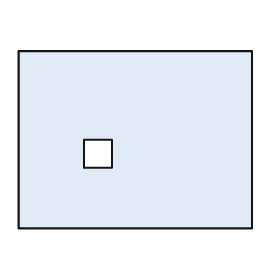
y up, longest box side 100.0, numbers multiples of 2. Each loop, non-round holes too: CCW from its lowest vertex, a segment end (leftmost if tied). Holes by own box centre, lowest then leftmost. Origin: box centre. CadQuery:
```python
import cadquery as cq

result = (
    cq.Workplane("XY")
    .moveTo(-50.0, -38.0)
    .lineTo(50.0, -38.0)
    .lineTo(50.0, 38.0)
    .lineTo(-50.0, 38.0)
    .close()
    .moveTo(-22.0, -12.0)
    .lineTo(-10.0, -12.0)
    .lineTo(-10.0, 0.0)
    .lineTo(-22.0, 0.0)
    .close()
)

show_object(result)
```